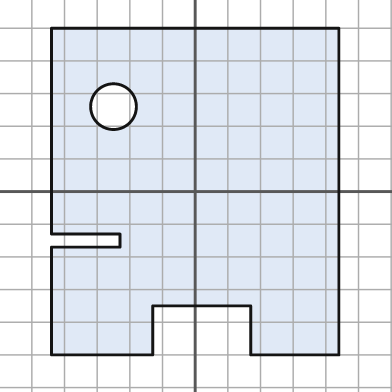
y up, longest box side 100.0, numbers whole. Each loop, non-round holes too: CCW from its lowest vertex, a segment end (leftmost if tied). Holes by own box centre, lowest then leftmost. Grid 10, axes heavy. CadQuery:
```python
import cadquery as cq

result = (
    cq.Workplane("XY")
    .moveTo(-44.0, -50.0)
    .lineTo(-13.0, -50.0)
    .lineTo(-13.0, -35.0)
    .lineTo(17.0, -35.0)
    .lineTo(17.0, -50.0)
    .lineTo(44.0, -50.0)
    .lineTo(44.0, 50.0)
    .lineTo(-44.0, 50.0)
    .lineTo(-44.0, -13.0)
    .lineTo(-23.0, -13.0)
    .lineTo(-23.0, -17.0)
    .lineTo(-44.0, -17.0)
    .close()
    .moveTo(-25.0, 26.0)
    .circle(7.0)
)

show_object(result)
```